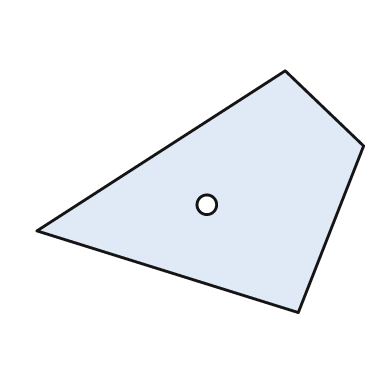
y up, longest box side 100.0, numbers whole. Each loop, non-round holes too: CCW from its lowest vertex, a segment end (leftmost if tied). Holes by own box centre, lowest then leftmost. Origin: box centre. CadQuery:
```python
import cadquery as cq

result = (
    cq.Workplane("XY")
    .moveTo(30.0, -37.0)
    .lineTo(50.0, 14.0)
    .lineTo(26.0, 37.0)
    .lineTo(-50.0, -12.0)
    .close()
    .moveTo(2.0, -4.0)
    .circle(3.0)
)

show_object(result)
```